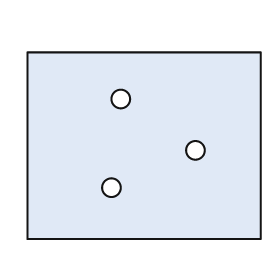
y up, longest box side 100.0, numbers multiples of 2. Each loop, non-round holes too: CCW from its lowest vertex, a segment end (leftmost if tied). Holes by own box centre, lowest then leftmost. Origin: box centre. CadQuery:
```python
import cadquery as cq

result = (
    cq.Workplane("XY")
    .moveTo(-50.0, -40.0)
    .lineTo(50.0, -40.0)
    .lineTo(50.0, 40.0)
    .lineTo(-50.0, 40.0)
    .close()
    .moveTo(-14.0, -18.0)
    .circle(4.0)
    .moveTo(22.0, -2.0)
    .circle(4.0)
    .moveTo(-10.0, 20.0)
    .circle(4.0)
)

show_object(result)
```